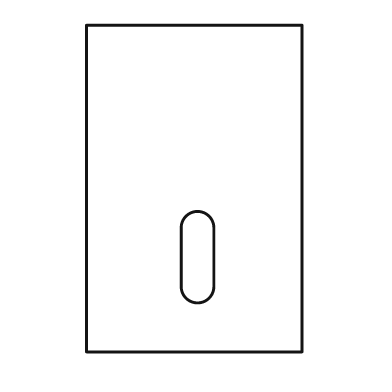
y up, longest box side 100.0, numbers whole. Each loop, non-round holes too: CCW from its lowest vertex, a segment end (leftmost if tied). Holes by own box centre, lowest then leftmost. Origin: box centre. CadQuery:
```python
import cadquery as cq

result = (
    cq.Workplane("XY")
    .moveTo(-33.0, -50.0)
    .lineTo(33.0, -50.0)
    .lineTo(33.0, 50.0)
    .lineTo(-33.0, 50.0)
    .close()
    .moveTo(-4.0, -30.0)
    .threePointArc((1.0, -35.0), (6.0, -30.0))
    .lineTo(6.0, -12.0)
    .threePointArc((1.0, -7.0), (-4.0, -12.0))
    .close()
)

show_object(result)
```